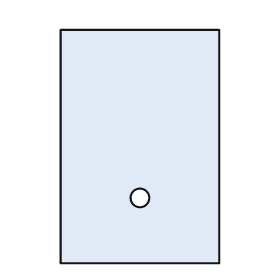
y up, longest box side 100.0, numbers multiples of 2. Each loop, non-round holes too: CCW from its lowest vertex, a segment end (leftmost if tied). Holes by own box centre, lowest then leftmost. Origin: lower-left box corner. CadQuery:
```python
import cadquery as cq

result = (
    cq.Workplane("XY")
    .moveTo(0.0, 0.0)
    .lineTo(68.0, 0.0)
    .lineTo(68.0, 100.0)
    .lineTo(0.0, 100.0)
    .close()
    .moveTo(34.0, 28.0)
    .circle(4.0)
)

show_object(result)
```